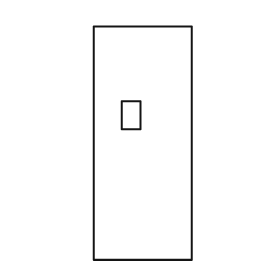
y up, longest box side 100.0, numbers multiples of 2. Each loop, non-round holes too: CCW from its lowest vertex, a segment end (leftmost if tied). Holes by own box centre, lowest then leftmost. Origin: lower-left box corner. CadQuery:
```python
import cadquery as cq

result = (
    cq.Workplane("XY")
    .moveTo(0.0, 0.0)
    .lineTo(42.0, 0.0)
    .lineTo(42.0, 100.0)
    .lineTo(0.0, 100.0)
    .close()
    .moveTo(12.0, 56.0)
    .lineTo(20.0, 56.0)
    .lineTo(20.0, 68.0)
    .lineTo(12.0, 68.0)
    .close()
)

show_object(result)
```